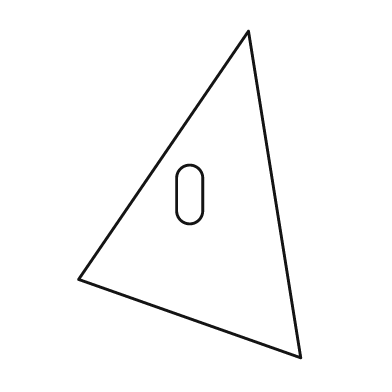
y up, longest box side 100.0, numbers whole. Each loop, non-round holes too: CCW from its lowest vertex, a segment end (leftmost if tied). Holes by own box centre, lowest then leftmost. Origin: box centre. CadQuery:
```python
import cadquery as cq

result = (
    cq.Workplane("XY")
    .moveTo(34.0, -50.0)
    .lineTo(18.0, 50.0)
    .lineTo(-34.0, -26.0)
    .close()
    .moveTo(-4.0, -5.0)
    .threePointArc((0.0, -9.0), (4.0, -5.0))
    .lineTo(4.0, 5.0)
    .threePointArc((0.0, 9.0), (-4.0, 5.0))
    .close()
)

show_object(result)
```